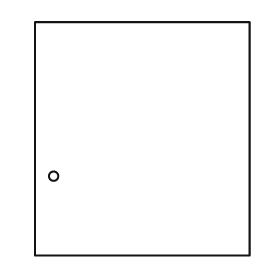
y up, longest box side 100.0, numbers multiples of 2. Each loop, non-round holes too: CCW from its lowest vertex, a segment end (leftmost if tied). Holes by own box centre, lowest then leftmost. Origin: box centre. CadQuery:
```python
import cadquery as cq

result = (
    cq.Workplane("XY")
    .moveTo(-46.0, -50.0)
    .lineTo(46.0, -50.0)
    .lineTo(46.0, 50.0)
    .lineTo(-46.0, 50.0)
    .close()
    .moveTo(-38.0, -16.0)
    .circle(2.0)
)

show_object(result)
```